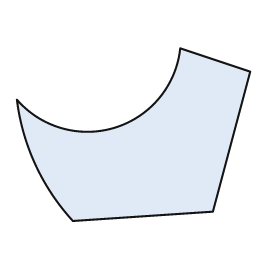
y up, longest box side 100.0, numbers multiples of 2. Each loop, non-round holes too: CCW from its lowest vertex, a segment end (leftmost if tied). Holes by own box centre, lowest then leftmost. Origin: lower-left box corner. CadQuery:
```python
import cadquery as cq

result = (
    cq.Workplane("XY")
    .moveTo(24.0, 0.0)
    .lineTo(84.0, 4.0)
    .lineTo(100.0, 64.0)
    .lineTo(70.0, 74.0)
    .threePointArc((42.0, 40.0), (0.0, 52.0))
    .threePointArc((8.0, 24.0), (24.0, 0.0))
    .close()
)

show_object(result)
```